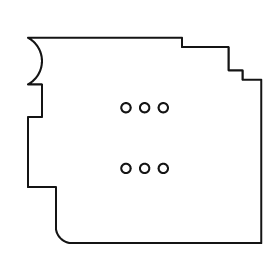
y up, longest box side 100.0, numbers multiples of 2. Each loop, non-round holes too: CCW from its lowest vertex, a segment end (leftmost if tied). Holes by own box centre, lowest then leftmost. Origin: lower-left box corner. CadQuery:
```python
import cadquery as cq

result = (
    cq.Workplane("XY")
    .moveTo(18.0, 0.0)
    .lineTo(100.0, 0.0)
    .lineTo(100.0, 70.0)
    .lineTo(92.0, 70.0)
    .lineTo(92.0, 74.0)
    .lineTo(86.0, 74.0)
    .lineTo(86.0, 84.0)
    .lineTo(66.0, 84.0)
    .lineTo(66.0, 88.0)
    .lineTo(0.0, 88.0)
    .threePointArc((6.0, 78.0), (0.0, 68.0))
    .lineTo(6.0, 68.0)
    .lineTo(6.0, 54.0)
    .lineTo(0.0, 54.0)
    .lineTo(0.0, 24.0)
    .lineTo(12.0, 24.0)
    .lineTo(12.0, 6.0)
    .threePointArc((14.0, 2.0), (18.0, 0.0))
    .close()
    .moveTo(42.0, 32.0)
    .circle(2.0)
    .moveTo(50.0, 32.0)
    .circle(2.0)
    .moveTo(58.0, 32.0)
    .circle(2.0)
    .moveTo(42.0, 58.0)
    .circle(2.0)
    .moveTo(50.0, 58.0)
    .circle(2.0)
    .moveTo(58.0, 58.0)
    .circle(2.0)
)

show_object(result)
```